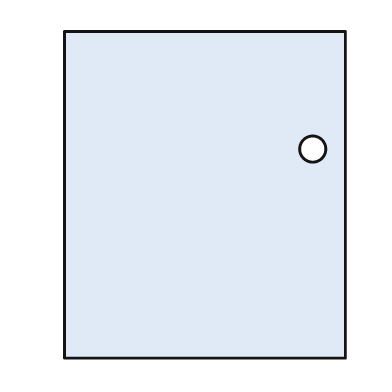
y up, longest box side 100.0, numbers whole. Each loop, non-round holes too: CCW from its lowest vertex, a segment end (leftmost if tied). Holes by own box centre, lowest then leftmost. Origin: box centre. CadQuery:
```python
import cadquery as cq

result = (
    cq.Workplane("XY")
    .moveTo(-43.0, -50.0)
    .lineTo(43.0, -50.0)
    .lineTo(43.0, 50.0)
    .lineTo(-43.0, 50.0)
    .close()
    .moveTo(33.0, 14.0)
    .circle(4.0)
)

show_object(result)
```